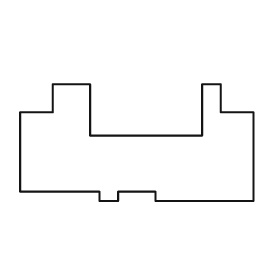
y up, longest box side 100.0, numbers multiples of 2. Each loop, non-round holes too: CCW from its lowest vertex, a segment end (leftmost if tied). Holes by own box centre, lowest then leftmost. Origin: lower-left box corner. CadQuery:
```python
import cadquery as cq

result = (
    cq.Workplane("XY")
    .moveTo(34.0, 0.0)
    .lineTo(42.0, 0.0)
    .lineTo(42.0, 4.0)
    .lineTo(58.0, 4.0)
    .lineTo(58.0, 0.0)
    .lineTo(100.0, 0.0)
    .lineTo(100.0, 38.0)
    .lineTo(86.0, 38.0)
    .lineTo(86.0, 50.0)
    .lineTo(78.0, 50.0)
    .lineTo(78.0, 28.0)
    .lineTo(30.0, 28.0)
    .lineTo(30.0, 50.0)
    .lineTo(14.0, 50.0)
    .lineTo(14.0, 38.0)
    .lineTo(0.0, 38.0)
    .lineTo(0.0, 4.0)
    .lineTo(34.0, 4.0)
    .close()
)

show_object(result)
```